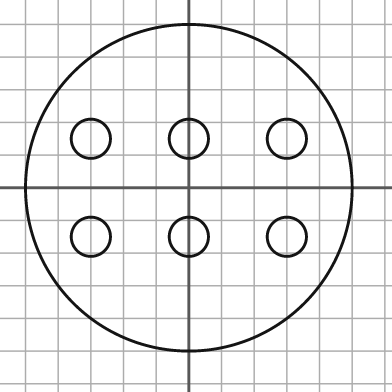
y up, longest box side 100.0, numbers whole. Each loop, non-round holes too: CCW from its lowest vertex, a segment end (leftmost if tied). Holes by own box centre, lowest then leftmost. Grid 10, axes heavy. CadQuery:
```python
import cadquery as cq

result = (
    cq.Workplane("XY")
    .moveTo(0.0, 0.0)
    .circle(50.0)
    .moveTo(-30.0, -15.0)
    .circle(6.0)
    .moveTo(0.0, -15.0)
    .circle(6.0)
    .moveTo(30.0, -15.0)
    .circle(6.0)
    .moveTo(-30.0, 15.0)
    .circle(6.0)
    .moveTo(0.0, 15.0)
    .circle(6.0)
    .moveTo(30.0, 15.0)
    .circle(6.0)
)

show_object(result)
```